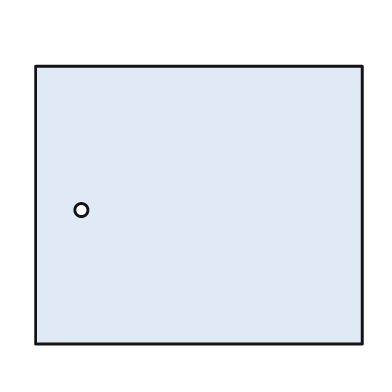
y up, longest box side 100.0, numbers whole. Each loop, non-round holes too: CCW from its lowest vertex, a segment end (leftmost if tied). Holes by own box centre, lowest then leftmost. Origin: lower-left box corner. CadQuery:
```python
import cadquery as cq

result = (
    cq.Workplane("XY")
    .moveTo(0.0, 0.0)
    .lineTo(100.0, 0.0)
    .lineTo(100.0, 85.0)
    .lineTo(0.0, 85.0)
    .close()
    .moveTo(14.0, 41.0)
    .circle(2.0)
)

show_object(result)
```